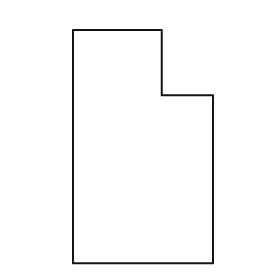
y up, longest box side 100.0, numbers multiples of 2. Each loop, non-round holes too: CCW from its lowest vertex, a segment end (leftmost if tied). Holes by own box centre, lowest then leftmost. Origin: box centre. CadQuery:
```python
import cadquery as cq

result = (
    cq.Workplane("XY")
    .moveTo(-30.0, -50.0)
    .lineTo(30.0, -50.0)
    .lineTo(30.0, 22.0)
    .lineTo(8.0, 22.0)
    .lineTo(8.0, 50.0)
    .lineTo(-30.0, 50.0)
    .close()
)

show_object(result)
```